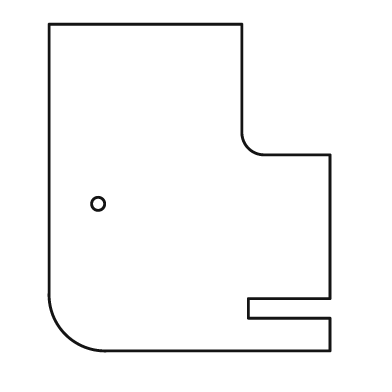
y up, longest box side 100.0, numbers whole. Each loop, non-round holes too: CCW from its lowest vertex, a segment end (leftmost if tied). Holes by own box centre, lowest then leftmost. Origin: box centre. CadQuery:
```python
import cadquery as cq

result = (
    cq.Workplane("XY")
    .moveTo(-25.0, -50.0)
    .lineTo(43.0, -50.0)
    .lineTo(43.0, -40.0)
    .lineTo(18.0, -40.0)
    .lineTo(18.0, -34.0)
    .lineTo(43.0, -34.0)
    .lineTo(43.0, 10.0)
    .lineTo(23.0, 10.0)
    .threePointArc((18.0, 12.0), (16.0, 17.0))
    .lineTo(16.0, 50.0)
    .lineTo(-43.0, 50.0)
    .lineTo(-43.0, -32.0)
    .threePointArc((-38.0, -45.0), (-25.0, -50.0))
    .close()
    .moveTo(-28.0, -5.0)
    .circle(2.0)
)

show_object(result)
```